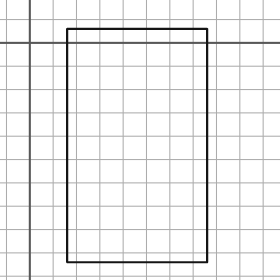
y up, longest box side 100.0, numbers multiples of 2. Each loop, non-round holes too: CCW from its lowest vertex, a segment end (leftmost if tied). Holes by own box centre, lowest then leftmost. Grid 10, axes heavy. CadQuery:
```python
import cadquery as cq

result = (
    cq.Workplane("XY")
    .moveTo(16.0, -94.0)
    .lineTo(76.0, -94.0)
    .lineTo(76.0, 6.0)
    .lineTo(16.0, 6.0)
    .close()
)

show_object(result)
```